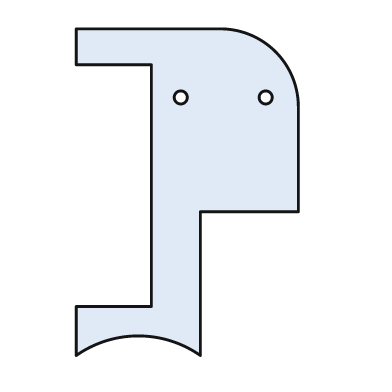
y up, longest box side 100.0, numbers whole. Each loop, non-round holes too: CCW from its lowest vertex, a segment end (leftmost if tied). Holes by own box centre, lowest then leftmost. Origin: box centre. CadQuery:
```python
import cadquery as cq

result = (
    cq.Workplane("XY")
    .moveTo(-34.0, -50.0)
    .threePointArc((-15.0, -44.0), (4.0, -50.0))
    .lineTo(4.0, -6.0)
    .lineTo(34.0, -6.0)
    .lineTo(34.0, 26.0)
    .threePointArc((27.0, 43.0), (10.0, 50.0))
    .lineTo(-34.0, 50.0)
    .lineTo(-34.0, 39.0)
    .lineTo(-11.0, 39.0)
    .lineTo(-11.0, -35.0)
    .lineTo(-34.0, -35.0)
    .close()
    .moveTo(-2.0, 29.0)
    .circle(2.0)
    .moveTo(24.0, 29.0)
    .circle(2.0)
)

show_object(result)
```